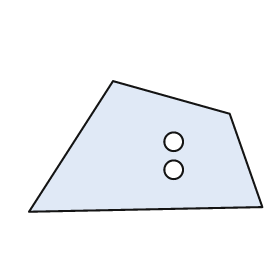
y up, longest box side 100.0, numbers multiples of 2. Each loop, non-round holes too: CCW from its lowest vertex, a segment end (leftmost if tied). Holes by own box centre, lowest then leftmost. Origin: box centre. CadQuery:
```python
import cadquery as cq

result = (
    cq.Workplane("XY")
    .moveTo(-50.0, -28.0)
    .lineTo(50.0, -26.0)
    .lineTo(36.0, 14.0)
    .lineTo(-14.0, 28.0)
    .close()
    .moveTo(12.0, -10.0)
    .circle(4.0)
    .moveTo(12.0, 2.0)
    .circle(4.0)
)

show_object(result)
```